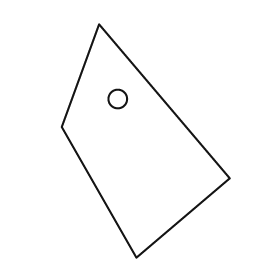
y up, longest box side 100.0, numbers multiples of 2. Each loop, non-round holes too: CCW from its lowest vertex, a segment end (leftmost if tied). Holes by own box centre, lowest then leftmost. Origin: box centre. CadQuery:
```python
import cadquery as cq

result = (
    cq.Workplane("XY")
    .moveTo(-4.0, -50.0)
    .lineTo(36.0, -16.0)
    .lineTo(-20.0, 50.0)
    .lineTo(-36.0, 6.0)
    .close()
    .moveTo(-12.0, 18.0)
    .circle(4.0)
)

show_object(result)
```